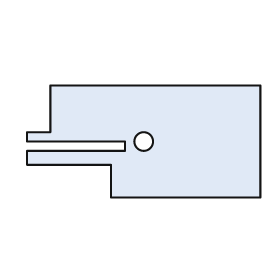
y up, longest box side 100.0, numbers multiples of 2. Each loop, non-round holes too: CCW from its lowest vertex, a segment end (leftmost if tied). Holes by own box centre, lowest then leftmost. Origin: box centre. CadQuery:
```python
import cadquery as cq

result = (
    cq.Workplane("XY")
    .moveTo(-14.0, -24.0)
    .lineTo(50.0, -24.0)
    .lineTo(50.0, 24.0)
    .lineTo(-40.0, 24.0)
    .lineTo(-40.0, 4.0)
    .lineTo(-50.0, 4.0)
    .lineTo(-50.0, 0.0)
    .lineTo(-8.0, 0.0)
    .lineTo(-8.0, -4.0)
    .lineTo(-50.0, -4.0)
    .lineTo(-50.0, -10.0)
    .lineTo(-14.0, -10.0)
    .close()
    .moveTo(0.0, 0.0)
    .circle(4.0)
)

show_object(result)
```